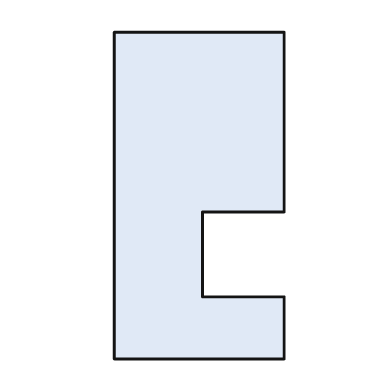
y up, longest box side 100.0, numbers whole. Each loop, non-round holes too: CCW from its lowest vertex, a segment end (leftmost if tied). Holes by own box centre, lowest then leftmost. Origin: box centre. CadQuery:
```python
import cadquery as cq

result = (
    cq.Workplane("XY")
    .moveTo(-26.0, -50.0)
    .lineTo(26.0, -50.0)
    .lineTo(26.0, -31.0)
    .lineTo(1.0, -31.0)
    .lineTo(1.0, -5.0)
    .lineTo(26.0, -5.0)
    .lineTo(26.0, 50.0)
    .lineTo(-26.0, 50.0)
    .close()
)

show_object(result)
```